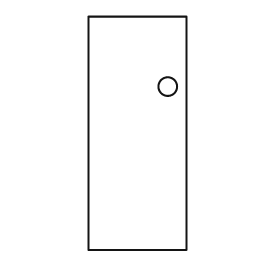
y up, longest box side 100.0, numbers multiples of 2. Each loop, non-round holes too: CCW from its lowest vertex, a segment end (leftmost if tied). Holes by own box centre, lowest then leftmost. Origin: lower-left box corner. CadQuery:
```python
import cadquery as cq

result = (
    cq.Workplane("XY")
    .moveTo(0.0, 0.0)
    .lineTo(42.0, 0.0)
    .lineTo(42.0, 100.0)
    .lineTo(0.0, 100.0)
    .close()
    .moveTo(34.0, 70.0)
    .circle(4.0)
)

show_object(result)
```